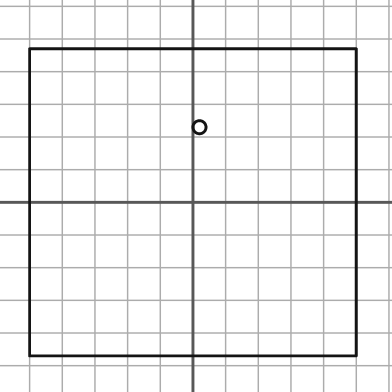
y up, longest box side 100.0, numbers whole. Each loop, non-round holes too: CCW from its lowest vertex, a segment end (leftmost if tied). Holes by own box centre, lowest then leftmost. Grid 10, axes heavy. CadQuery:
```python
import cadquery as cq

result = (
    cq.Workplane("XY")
    .moveTo(-50.0, -47.0)
    .lineTo(50.0, -47.0)
    .lineTo(50.0, 47.0)
    .lineTo(-50.0, 47.0)
    .close()
    .moveTo(2.0, 23.0)
    .circle(2.0)
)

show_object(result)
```